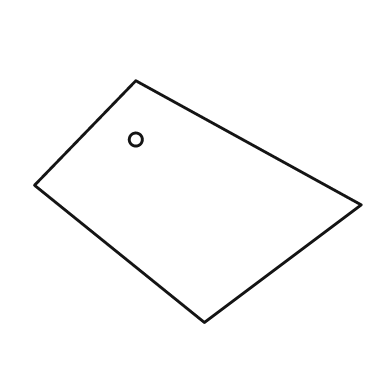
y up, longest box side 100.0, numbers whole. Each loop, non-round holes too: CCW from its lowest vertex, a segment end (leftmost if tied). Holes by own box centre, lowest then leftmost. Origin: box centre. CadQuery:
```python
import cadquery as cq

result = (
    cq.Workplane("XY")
    .moveTo(2.0, -37.0)
    .lineTo(50.0, -1.0)
    .lineTo(-19.0, 37.0)
    .lineTo(-50.0, 5.0)
    .close()
    .moveTo(-19.0, 19.0)
    .circle(2.0)
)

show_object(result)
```